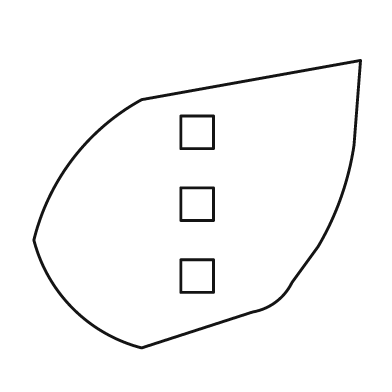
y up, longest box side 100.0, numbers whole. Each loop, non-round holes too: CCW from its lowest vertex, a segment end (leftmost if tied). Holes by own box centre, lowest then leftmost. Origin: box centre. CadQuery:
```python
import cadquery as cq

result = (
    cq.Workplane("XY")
    .moveTo(-17.0, -44.0)
    .lineTo(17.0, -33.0)
    .threePointArc((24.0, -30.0), (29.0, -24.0))
    .lineTo(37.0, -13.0)
    .threePointArc((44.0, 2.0), (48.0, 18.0))
    .lineTo(50.0, 44.0)
    .lineTo(-17.0, 32.0)
    .threePointArc((-38.0, 14.0), (-50.0, -11.0))
    .threePointArc((-38.0, -32.0), (-17.0, -44.0))
    .close()
    .moveTo(-5.0, -27.0)
    .lineTo(5.0, -27.0)
    .lineTo(5.0, -17.0)
    .lineTo(-5.0, -17.0)
    .close()
    .moveTo(-5.0, -5.0)
    .lineTo(5.0, -5.0)
    .lineTo(5.0, 5.0)
    .lineTo(-5.0, 5.0)
    .close()
    .moveTo(-5.0, 17.0)
    .lineTo(5.0, 17.0)
    .lineTo(5.0, 27.0)
    .lineTo(-5.0, 27.0)
    .close()
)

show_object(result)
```